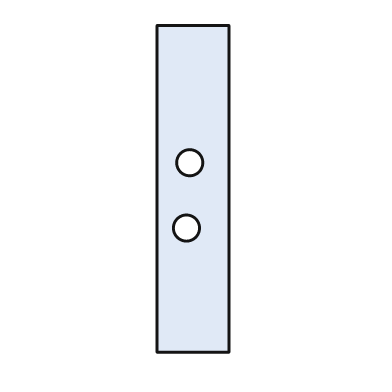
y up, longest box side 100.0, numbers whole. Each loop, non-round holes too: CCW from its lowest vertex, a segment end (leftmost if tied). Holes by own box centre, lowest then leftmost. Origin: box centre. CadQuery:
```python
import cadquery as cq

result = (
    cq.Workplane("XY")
    .moveTo(-11.0, -50.0)
    .lineTo(11.0, -50.0)
    .lineTo(11.0, 50.0)
    .lineTo(-11.0, 50.0)
    .close()
    .moveTo(-2.0, -12.0)
    .circle(4.0)
    .moveTo(-1.0, 8.0)
    .circle(4.0)
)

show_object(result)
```